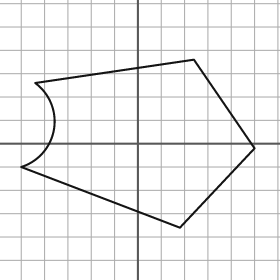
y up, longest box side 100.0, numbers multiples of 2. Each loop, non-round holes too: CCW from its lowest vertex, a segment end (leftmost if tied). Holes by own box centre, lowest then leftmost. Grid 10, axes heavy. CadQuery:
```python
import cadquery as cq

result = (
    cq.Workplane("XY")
    .moveTo(18.0, -36.0)
    .lineTo(50.0, -2.0)
    .lineTo(24.0, 36.0)
    .lineTo(-44.0, 26.0)
    .threePointArc((-36.0, 6.0), (-50.0, -10.0))
    .close()
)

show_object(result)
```